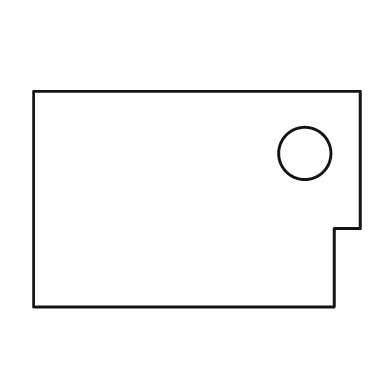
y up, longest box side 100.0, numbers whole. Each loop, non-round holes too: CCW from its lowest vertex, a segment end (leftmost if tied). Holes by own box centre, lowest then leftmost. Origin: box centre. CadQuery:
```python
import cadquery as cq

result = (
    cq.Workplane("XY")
    .moveTo(-50.0, -33.0)
    .lineTo(42.0, -33.0)
    .lineTo(42.0, -9.0)
    .lineTo(50.0, -9.0)
    .lineTo(50.0, 33.0)
    .lineTo(-50.0, 33.0)
    .close()
    .moveTo(33.0, 14.0)
    .circle(8.0)
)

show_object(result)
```